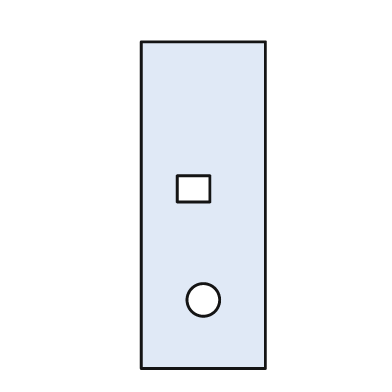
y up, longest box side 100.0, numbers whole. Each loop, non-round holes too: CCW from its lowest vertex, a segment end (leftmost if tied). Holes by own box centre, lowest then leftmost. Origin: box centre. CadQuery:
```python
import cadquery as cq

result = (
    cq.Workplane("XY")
    .moveTo(-19.0, -50.0)
    .lineTo(19.0, -50.0)
    .lineTo(19.0, 50.0)
    .lineTo(-19.0, 50.0)
    .close()
    .moveTo(0.0, -29.0)
    .circle(5.0)
    .moveTo(-8.0, 1.0)
    .lineTo(2.0, 1.0)
    .lineTo(2.0, 9.0)
    .lineTo(-8.0, 9.0)
    .close()
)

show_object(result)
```